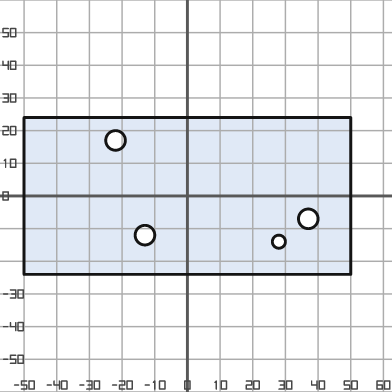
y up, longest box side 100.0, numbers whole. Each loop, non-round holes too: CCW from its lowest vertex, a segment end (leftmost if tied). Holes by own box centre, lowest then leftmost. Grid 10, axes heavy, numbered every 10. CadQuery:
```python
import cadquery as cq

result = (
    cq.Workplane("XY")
    .moveTo(-50.0, -24.0)
    .lineTo(50.0, -24.0)
    .lineTo(50.0, 24.0)
    .lineTo(-50.0, 24.0)
    .close()
    .moveTo(28.0, -14.0)
    .circle(2.0)
    .moveTo(-13.0, -12.0)
    .circle(3.0)
    .moveTo(37.0, -7.0)
    .circle(3.0)
    .moveTo(-22.0, 17.0)
    .circle(3.0)
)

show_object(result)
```